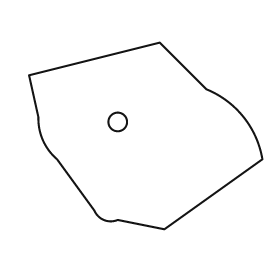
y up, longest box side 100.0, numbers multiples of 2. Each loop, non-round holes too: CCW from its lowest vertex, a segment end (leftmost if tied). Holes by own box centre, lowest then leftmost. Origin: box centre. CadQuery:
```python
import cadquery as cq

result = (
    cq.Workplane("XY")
    .moveTo(8.0, -40.0)
    .lineTo(50.0, -10.0)
    .threePointArc((42.0, 8.0), (26.0, 20.0))
    .lineTo(6.0, 40.0)
    .lineTo(-50.0, 26.0)
    .lineTo(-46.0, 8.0)
    .threePointArc((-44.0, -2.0), (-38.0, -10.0))
    .lineTo(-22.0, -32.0)
    .threePointArc((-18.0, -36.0), (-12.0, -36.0))
    .close()
    .moveTo(-12.0, 6.0)
    .circle(4.0)
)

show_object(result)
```